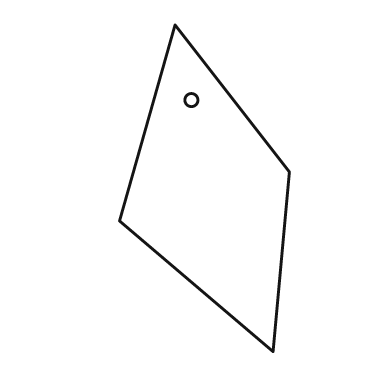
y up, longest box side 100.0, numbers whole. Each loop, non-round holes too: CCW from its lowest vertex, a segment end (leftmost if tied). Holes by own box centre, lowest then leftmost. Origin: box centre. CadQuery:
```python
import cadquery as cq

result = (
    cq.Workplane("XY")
    .moveTo(21.0, -50.0)
    .lineTo(26.0, 5.0)
    .lineTo(-9.0, 50.0)
    .lineTo(-26.0, -10.0)
    .close()
    .moveTo(-4.0, 27.0)
    .circle(2.0)
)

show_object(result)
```